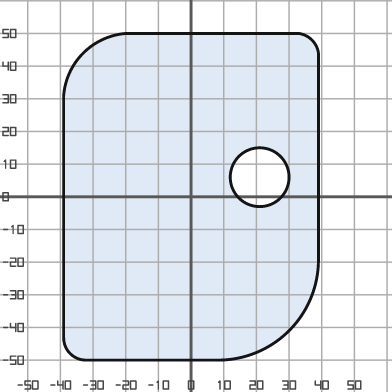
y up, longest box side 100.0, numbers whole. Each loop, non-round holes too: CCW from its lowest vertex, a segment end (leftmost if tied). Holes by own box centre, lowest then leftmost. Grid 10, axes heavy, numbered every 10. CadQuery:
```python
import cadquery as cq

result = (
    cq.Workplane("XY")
    .moveTo(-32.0, -50.0)
    .lineTo(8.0, -50.0)
    .threePointArc((30.0, -41.0), (39.0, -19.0))
    .lineTo(39.0, 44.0)
    .threePointArc((37.0, 48.0), (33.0, 50.0))
    .lineTo(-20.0, 50.0)
    .threePointArc((-33.0, 44.0), (-39.0, 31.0))
    .lineTo(-39.0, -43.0)
    .threePointArc((-37.0, -48.0), (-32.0, -50.0))
    .close()
    .moveTo(21.0, 6.0)
    .circle(9.0)
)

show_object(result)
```